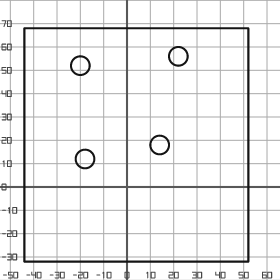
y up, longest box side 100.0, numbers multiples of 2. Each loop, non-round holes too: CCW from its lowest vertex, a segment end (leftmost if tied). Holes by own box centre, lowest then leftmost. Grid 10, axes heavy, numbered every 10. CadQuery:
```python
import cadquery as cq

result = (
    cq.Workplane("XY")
    .moveTo(-44.0, -32.0)
    .lineTo(52.0, -32.0)
    .lineTo(52.0, 68.0)
    .lineTo(-44.0, 68.0)
    .close()
    .moveTo(-18.0, 12.0)
    .circle(4.0)
    .moveTo(14.0, 18.0)
    .circle(4.0)
    .moveTo(-20.0, 52.0)
    .circle(4.0)
    .moveTo(22.0, 56.0)
    .circle(4.0)
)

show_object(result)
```